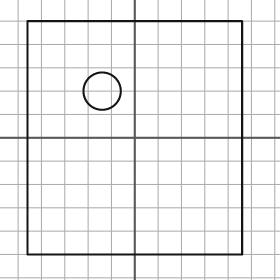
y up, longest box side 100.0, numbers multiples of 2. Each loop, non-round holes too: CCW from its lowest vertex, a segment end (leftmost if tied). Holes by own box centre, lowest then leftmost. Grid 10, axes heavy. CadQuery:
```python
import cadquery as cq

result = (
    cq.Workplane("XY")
    .moveTo(-46.0, -50.0)
    .lineTo(46.0, -50.0)
    .lineTo(46.0, 50.0)
    .lineTo(-46.0, 50.0)
    .close()
    .moveTo(-14.0, 20.0)
    .circle(8.0)
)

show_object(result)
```